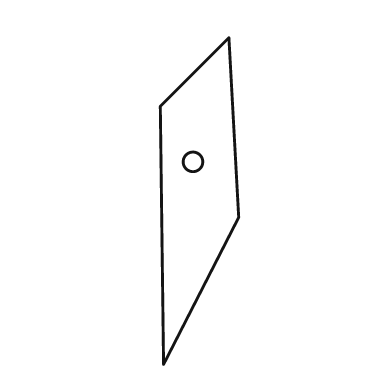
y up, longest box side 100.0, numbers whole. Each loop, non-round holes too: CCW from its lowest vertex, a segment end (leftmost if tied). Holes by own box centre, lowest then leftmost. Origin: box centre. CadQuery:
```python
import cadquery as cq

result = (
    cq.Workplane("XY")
    .moveTo(-11.0, -50.0)
    .lineTo(12.0, -5.0)
    .lineTo(9.0, 50.0)
    .lineTo(-12.0, 29.0)
    .close()
    .moveTo(-2.0, 12.0)
    .circle(3.0)
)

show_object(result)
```